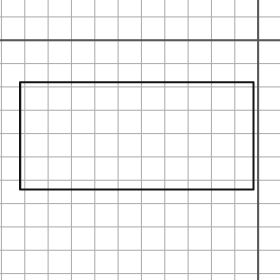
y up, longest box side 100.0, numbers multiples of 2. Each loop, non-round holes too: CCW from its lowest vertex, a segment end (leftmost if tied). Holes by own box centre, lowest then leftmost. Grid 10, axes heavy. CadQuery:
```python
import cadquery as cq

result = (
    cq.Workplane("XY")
    .moveTo(-102.0, -64.0)
    .lineTo(-2.0, -64.0)
    .lineTo(-2.0, -18.0)
    .lineTo(-102.0, -18.0)
    .close()
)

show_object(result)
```